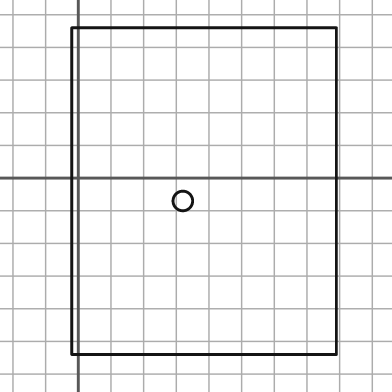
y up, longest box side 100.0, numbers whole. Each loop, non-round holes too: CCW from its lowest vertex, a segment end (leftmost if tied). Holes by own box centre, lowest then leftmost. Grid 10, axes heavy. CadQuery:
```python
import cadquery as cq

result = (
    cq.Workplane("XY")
    .moveTo(-2.0, -54.0)
    .lineTo(79.0, -54.0)
    .lineTo(79.0, 46.0)
    .lineTo(-2.0, 46.0)
    .close()
    .moveTo(32.0, -7.0)
    .circle(3.0)
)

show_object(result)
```